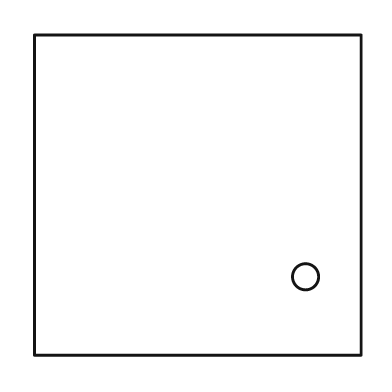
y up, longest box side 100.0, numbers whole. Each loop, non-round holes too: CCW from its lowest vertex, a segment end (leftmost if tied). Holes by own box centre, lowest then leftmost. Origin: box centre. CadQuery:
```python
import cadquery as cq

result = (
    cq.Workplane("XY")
    .moveTo(-50.0, -49.0)
    .lineTo(50.0, -49.0)
    .lineTo(50.0, 49.0)
    .lineTo(-50.0, 49.0)
    .close()
    .moveTo(33.0, -25.0)
    .circle(4.0)
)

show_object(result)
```